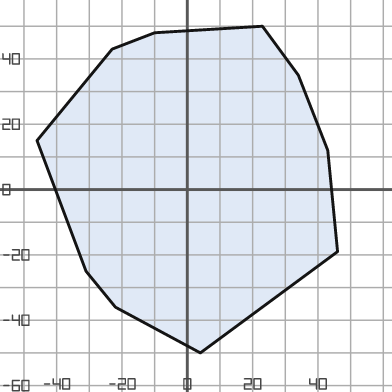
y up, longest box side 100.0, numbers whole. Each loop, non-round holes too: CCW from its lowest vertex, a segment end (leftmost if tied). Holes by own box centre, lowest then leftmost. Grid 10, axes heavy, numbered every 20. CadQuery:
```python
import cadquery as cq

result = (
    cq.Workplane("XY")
    .moveTo(4.0, -50.0)
    .lineTo(46.0, -19.0)
    .lineTo(43.0, 12.0)
    .lineTo(34.0, 35.0)
    .lineTo(23.0, 50.0)
    .lineTo(-10.0, 48.0)
    .lineTo(-23.0, 43.0)
    .lineTo(-46.0, 15.0)
    .lineTo(-31.0, -25.0)
    .lineTo(-22.0, -36.0)
    .close()
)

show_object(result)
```